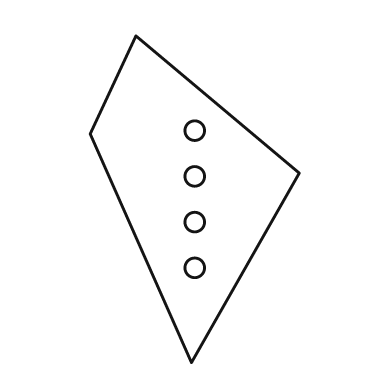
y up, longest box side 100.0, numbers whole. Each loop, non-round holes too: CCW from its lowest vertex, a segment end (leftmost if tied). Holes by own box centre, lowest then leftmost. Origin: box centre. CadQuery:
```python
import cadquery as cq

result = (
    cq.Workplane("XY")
    .moveTo(-1.0, -50.0)
    .lineTo(32.0, 8.0)
    .lineTo(-18.0, 50.0)
    .lineTo(-32.0, 20.0)
    .close()
    .moveTo(0.0, -21.0)
    .circle(3.0)
    .moveTo(0.0, -7.0)
    .circle(3.0)
    .moveTo(0.0, 7.0)
    .circle(3.0)
    .moveTo(0.0, 21.0)
    .circle(3.0)
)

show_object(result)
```